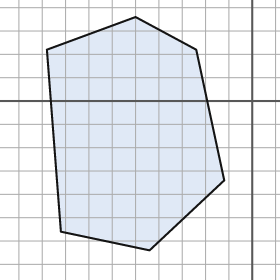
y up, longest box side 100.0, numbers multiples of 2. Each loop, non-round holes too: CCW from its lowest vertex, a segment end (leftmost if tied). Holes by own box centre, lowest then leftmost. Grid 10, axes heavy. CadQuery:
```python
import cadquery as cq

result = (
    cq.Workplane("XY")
    .moveTo(-44.0, -64.0)
    .lineTo(-12.0, -34.0)
    .lineTo(-24.0, 22.0)
    .lineTo(-50.0, 36.0)
    .lineTo(-88.0, 22.0)
    .lineTo(-82.0, -56.0)
    .close()
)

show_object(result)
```